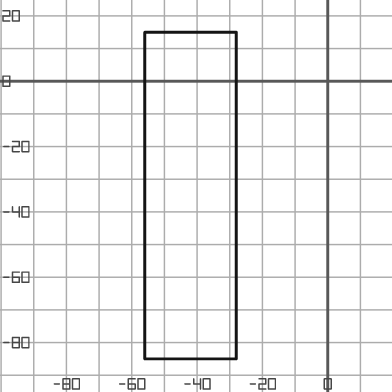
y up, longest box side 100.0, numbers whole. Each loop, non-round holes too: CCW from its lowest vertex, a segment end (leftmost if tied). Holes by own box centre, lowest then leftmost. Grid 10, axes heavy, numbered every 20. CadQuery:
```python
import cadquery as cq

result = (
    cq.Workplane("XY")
    .moveTo(-56.0, -85.0)
    .lineTo(-28.0, -85.0)
    .lineTo(-28.0, 15.0)
    .lineTo(-56.0, 15.0)
    .close()
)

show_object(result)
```